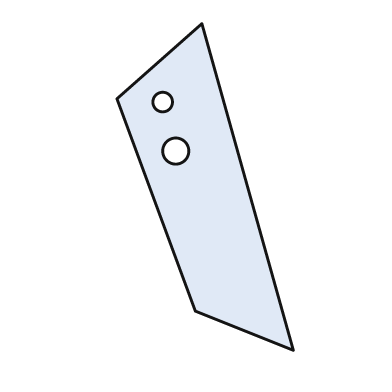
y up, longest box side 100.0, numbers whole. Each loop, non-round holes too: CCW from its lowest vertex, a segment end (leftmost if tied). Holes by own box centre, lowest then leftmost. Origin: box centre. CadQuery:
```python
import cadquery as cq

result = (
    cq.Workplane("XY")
    .moveTo(27.0, -50.0)
    .lineTo(-1.0, 50.0)
    .lineTo(-27.0, 27.0)
    .lineTo(-3.0, -38.0)
    .close()
    .moveTo(-9.0, 11.0)
    .circle(4.0)
    .moveTo(-13.0, 26.0)
    .circle(3.0)
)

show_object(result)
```